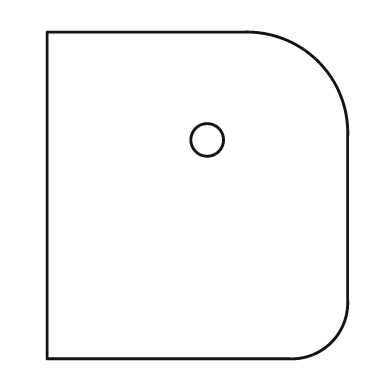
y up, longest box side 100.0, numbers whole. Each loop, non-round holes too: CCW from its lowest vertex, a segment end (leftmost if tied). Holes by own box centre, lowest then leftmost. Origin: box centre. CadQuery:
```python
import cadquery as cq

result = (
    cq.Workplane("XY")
    .moveTo(-46.0, -50.0)
    .lineTo(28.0, -50.0)
    .threePointArc((41.0, -45.0), (46.0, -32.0))
    .lineTo(46.0, 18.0)
    .threePointArc((37.0, 41.0), (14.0, 50.0))
    .lineTo(-46.0, 50.0)
    .close()
    .moveTo(3.0, 17.0)
    .circle(5.0)
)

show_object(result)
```